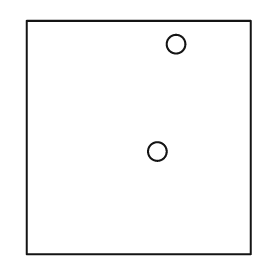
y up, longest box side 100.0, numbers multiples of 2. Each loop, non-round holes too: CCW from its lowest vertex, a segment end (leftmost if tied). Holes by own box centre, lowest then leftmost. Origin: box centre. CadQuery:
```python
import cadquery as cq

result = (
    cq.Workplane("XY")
    .moveTo(-48.0, -50.0)
    .lineTo(48.0, -50.0)
    .lineTo(48.0, 50.0)
    .lineTo(-48.0, 50.0)
    .close()
    .moveTo(8.0, -6.0)
    .circle(4.0)
    .moveTo(16.0, 40.0)
    .circle(4.0)
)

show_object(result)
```